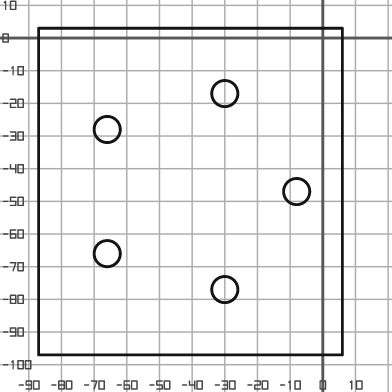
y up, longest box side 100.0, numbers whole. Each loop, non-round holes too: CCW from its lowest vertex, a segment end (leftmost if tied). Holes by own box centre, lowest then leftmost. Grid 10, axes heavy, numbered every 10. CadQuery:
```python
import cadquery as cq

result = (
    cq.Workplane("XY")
    .moveTo(-87.0, -97.0)
    .lineTo(6.0, -97.0)
    .lineTo(6.0, 3.0)
    .lineTo(-87.0, 3.0)
    .close()
    .moveTo(-30.0, -77.0)
    .circle(4.0)
    .moveTo(-66.0, -66.0)
    .circle(4.0)
    .moveTo(-8.0, -47.0)
    .circle(4.0)
    .moveTo(-66.0, -28.0)
    .circle(4.0)
    .moveTo(-30.0, -17.0)
    .circle(4.0)
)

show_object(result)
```